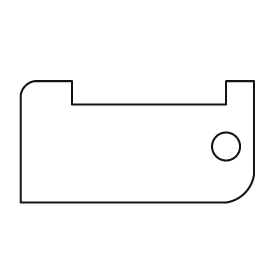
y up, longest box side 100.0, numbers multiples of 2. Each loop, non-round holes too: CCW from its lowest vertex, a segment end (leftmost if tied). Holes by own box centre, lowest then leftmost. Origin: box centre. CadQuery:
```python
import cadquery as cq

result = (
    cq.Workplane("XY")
    .moveTo(-50.0, -26.0)
    .lineTo(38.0, -26.0)
    .threePointArc((46.0, -22.0), (50.0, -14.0))
    .lineTo(50.0, 26.0)
    .lineTo(38.0, 26.0)
    .lineTo(38.0, 16.0)
    .lineTo(-28.0, 16.0)
    .lineTo(-28.0, 26.0)
    .lineTo(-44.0, 26.0)
    .threePointArc((-48.0, 24.0), (-50.0, 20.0))
    .close()
    .moveTo(38.0, -2.0)
    .circle(6.0)
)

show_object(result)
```